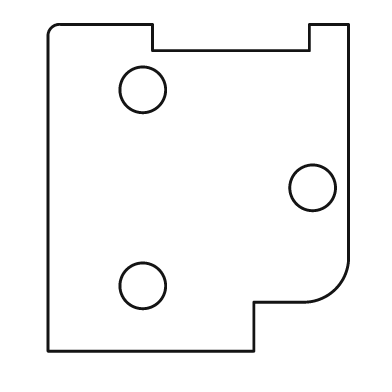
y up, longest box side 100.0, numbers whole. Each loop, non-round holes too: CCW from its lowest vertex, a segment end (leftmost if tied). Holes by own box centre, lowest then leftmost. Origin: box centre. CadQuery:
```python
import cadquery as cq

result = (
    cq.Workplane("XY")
    .moveTo(-46.0, -50.0)
    .lineTo(17.0, -50.0)
    .lineTo(17.0, -35.0)
    .lineTo(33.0, -35.0)
    .threePointArc((42.0, -31.0), (46.0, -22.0))
    .lineTo(46.0, 50.0)
    .lineTo(34.0, 50.0)
    .lineTo(34.0, 42.0)
    .lineTo(-14.0, 42.0)
    .lineTo(-14.0, 50.0)
    .lineTo(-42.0, 50.0)
    .threePointArc((-45.0, 49.0), (-46.0, 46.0))
    .close()
    .moveTo(-17.0, -30.0)
    .circle(7.0)
    .moveTo(35.0, 0.0)
    .circle(7.0)
    .moveTo(-17.0, 30.0)
    .circle(7.0)
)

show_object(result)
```